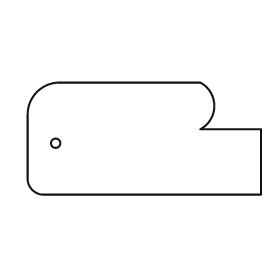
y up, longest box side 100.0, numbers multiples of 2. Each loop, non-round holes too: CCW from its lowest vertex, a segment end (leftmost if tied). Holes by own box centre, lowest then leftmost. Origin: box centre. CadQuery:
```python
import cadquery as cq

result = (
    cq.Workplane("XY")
    .moveTo(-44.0, -24.0)
    .lineTo(50.0, -24.0)
    .lineTo(50.0, 4.0)
    .lineTo(24.0, 4.0)
    .threePointArc((30.0, 14.0), (24.0, 24.0))
    .lineTo(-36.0, 24.0)
    .threePointArc((-46.0, 20.0), (-50.0, 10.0))
    .lineTo(-50.0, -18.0)
    .threePointArc((-48.0, -22.0), (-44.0, -24.0))
    .close()
    .moveTo(-38.0, -2.0)
    .circle(2.0)
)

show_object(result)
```